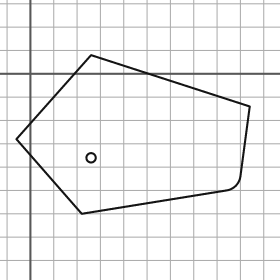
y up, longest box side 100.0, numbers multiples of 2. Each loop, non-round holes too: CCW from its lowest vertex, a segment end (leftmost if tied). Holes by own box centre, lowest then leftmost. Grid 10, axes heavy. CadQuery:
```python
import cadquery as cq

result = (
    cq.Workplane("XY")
    .moveTo(22.0, -60.0)
    .lineTo(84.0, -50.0)
    .threePointArc((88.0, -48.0), (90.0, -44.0))
    .lineTo(94.0, -14.0)
    .lineTo(26.0, 8.0)
    .lineTo(-6.0, -28.0)
    .close()
    .moveTo(26.0, -36.0)
    .circle(2.0)
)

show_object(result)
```